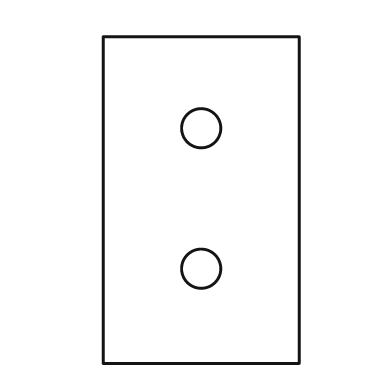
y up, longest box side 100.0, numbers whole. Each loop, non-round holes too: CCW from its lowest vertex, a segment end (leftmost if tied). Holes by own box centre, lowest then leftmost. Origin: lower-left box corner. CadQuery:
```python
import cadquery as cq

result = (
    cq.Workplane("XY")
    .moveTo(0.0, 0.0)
    .lineTo(60.0, 0.0)
    .lineTo(60.0, 100.0)
    .lineTo(0.0, 100.0)
    .close()
    .moveTo(30.0, 29.0)
    .circle(6.0)
    .moveTo(30.0, 72.0)
    .circle(6.0)
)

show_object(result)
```